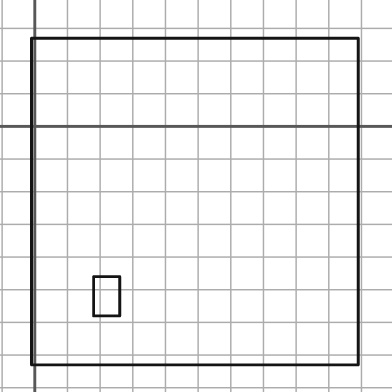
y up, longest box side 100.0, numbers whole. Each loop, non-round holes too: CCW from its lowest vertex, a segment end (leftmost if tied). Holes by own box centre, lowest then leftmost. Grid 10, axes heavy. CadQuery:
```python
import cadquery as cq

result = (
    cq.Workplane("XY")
    .moveTo(-1.0, -73.0)
    .lineTo(99.0, -73.0)
    .lineTo(99.0, 27.0)
    .lineTo(-1.0, 27.0)
    .close()
    .moveTo(18.0, -58.0)
    .lineTo(26.0, -58.0)
    .lineTo(26.0, -46.0)
    .lineTo(18.0, -46.0)
    .close()
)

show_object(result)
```